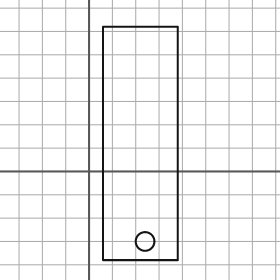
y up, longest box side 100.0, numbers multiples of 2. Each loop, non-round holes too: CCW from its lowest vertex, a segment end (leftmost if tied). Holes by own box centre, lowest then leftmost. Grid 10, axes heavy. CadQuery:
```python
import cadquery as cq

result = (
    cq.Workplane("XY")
    .moveTo(6.0, -38.0)
    .lineTo(38.0, -38.0)
    .lineTo(38.0, 62.0)
    .lineTo(6.0, 62.0)
    .close()
    .moveTo(24.0, -30.0)
    .circle(4.0)
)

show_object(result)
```